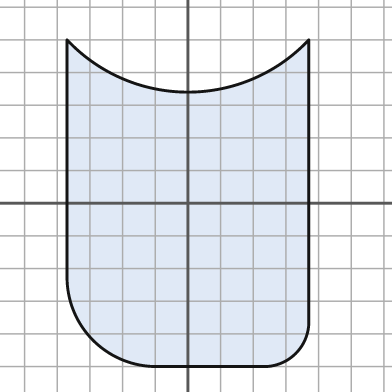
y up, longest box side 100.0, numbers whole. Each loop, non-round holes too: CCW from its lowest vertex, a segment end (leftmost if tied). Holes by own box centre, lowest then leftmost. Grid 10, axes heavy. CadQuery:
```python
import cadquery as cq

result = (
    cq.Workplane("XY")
    .moveTo(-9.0, -50.0)
    .lineTo(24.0, -50.0)
    .threePointArc((33.0, -46.0), (37.0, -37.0))
    .lineTo(37.0, 50.0)
    .threePointArc((0.0, 34.0), (-37.0, 50.0))
    .lineTo(-37.0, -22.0)
    .threePointArc((-29.0, -42.0), (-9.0, -50.0))
    .close()
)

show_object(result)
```